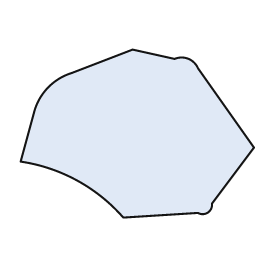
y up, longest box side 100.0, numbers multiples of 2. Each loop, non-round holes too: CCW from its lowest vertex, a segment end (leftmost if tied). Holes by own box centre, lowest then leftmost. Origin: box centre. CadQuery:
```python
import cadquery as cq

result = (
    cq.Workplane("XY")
    .moveTo(-6.0, -36.0)
    .lineTo(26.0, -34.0)
    .threePointArc((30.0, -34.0), (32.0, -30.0))
    .lineTo(50.0, -6.0)
    .lineTo(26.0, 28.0)
    .threePointArc((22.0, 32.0), (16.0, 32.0))
    .lineTo(-2.0, 36.0)
    .lineTo(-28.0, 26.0)
    .threePointArc((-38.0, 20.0), (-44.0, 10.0))
    .lineTo(-50.0, -12.0)
    .threePointArc((-26.0, -20.0), (-6.0, -36.0))
    .close()
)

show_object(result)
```